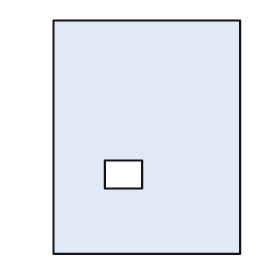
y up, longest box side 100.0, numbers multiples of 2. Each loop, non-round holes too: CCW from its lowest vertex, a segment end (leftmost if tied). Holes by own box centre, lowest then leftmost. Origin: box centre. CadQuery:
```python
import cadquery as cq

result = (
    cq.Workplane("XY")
    .moveTo(-40.0, -50.0)
    .lineTo(40.0, -50.0)
    .lineTo(40.0, 50.0)
    .lineTo(-40.0, 50.0)
    .close()
    .moveTo(-18.0, -22.0)
    .lineTo(-2.0, -22.0)
    .lineTo(-2.0, -10.0)
    .lineTo(-18.0, -10.0)
    .close()
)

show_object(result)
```